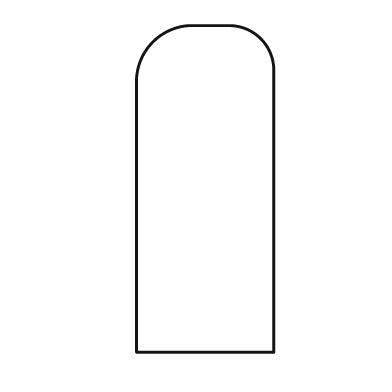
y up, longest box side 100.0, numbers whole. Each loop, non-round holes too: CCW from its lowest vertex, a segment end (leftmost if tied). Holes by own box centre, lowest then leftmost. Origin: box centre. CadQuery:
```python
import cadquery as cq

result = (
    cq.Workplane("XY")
    .moveTo(-21.0, -50.0)
    .lineTo(21.0, -50.0)
    .lineTo(21.0, 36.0)
    .threePointArc((17.0, 46.0), (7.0, 50.0))
    .lineTo(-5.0, 50.0)
    .threePointArc((-16.0, 45.0), (-21.0, 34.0))
    .close()
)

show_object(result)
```